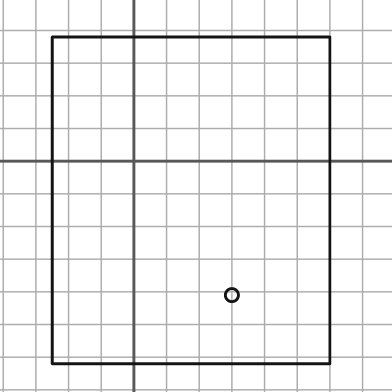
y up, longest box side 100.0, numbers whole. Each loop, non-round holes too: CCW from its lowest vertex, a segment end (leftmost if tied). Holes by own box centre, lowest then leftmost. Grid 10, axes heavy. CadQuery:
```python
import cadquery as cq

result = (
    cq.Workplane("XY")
    .moveTo(-25.0, -62.0)
    .lineTo(60.0, -62.0)
    .lineTo(60.0, 38.0)
    .lineTo(-25.0, 38.0)
    .close()
    .moveTo(30.0, -41.0)
    .circle(2.0)
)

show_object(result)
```